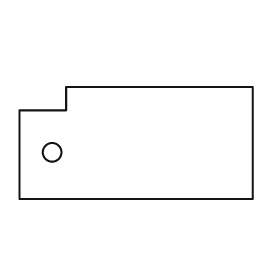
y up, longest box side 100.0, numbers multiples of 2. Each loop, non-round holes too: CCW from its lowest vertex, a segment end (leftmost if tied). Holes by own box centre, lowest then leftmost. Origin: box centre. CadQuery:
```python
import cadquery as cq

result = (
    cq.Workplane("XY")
    .moveTo(-50.0, -24.0)
    .lineTo(50.0, -24.0)
    .lineTo(50.0, 24.0)
    .lineTo(-30.0, 24.0)
    .lineTo(-30.0, 14.0)
    .lineTo(-50.0, 14.0)
    .close()
    .moveTo(-36.0, -4.0)
    .circle(4.0)
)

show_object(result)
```